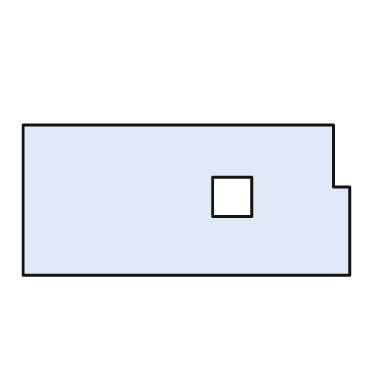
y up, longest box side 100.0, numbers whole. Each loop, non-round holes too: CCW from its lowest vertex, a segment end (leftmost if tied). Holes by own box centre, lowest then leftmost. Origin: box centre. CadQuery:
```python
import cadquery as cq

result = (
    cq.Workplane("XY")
    .moveTo(-50.0, -23.0)
    .lineTo(50.0, -23.0)
    .lineTo(50.0, 4.0)
    .lineTo(45.0, 4.0)
    .lineTo(45.0, 23.0)
    .lineTo(-50.0, 23.0)
    .close()
    .moveTo(8.0, -5.0)
    .lineTo(20.0, -5.0)
    .lineTo(20.0, 7.0)
    .lineTo(8.0, 7.0)
    .close()
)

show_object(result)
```